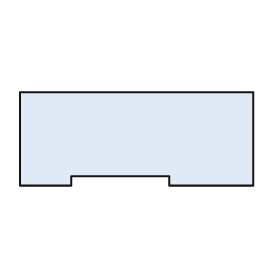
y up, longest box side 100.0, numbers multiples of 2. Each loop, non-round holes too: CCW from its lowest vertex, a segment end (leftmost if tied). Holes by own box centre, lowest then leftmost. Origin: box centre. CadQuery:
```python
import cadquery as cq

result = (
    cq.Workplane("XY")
    .moveTo(-50.0, -20.0)
    .lineTo(-28.0, -20.0)
    .lineTo(-28.0, -16.0)
    .lineTo(14.0, -16.0)
    .lineTo(14.0, -20.0)
    .lineTo(50.0, -20.0)
    .lineTo(50.0, 20.0)
    .lineTo(-50.0, 20.0)
    .close()
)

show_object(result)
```